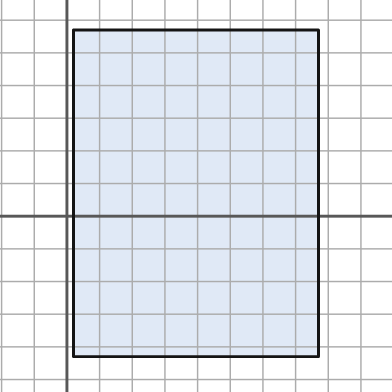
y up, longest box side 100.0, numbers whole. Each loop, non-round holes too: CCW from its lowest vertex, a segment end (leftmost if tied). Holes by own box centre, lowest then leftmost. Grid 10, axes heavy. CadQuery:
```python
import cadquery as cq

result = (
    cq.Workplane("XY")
    .moveTo(2.0, -43.0)
    .lineTo(77.0, -43.0)
    .lineTo(77.0, 57.0)
    .lineTo(2.0, 57.0)
    .close()
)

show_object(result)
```